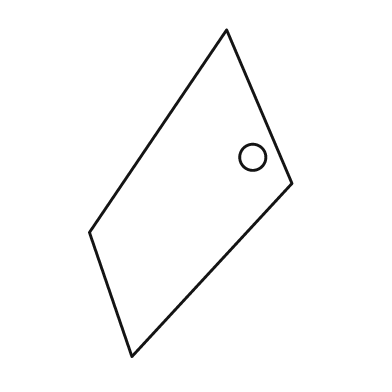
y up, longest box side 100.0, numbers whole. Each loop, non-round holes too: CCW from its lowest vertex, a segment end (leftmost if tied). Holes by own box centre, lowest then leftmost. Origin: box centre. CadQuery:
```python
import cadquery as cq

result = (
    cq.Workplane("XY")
    .moveTo(-18.0, -50.0)
    .lineTo(31.0, 3.0)
    .lineTo(11.0, 50.0)
    .lineTo(-31.0, -12.0)
    .close()
    .moveTo(19.0, 11.0)
    .circle(4.0)
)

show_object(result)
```